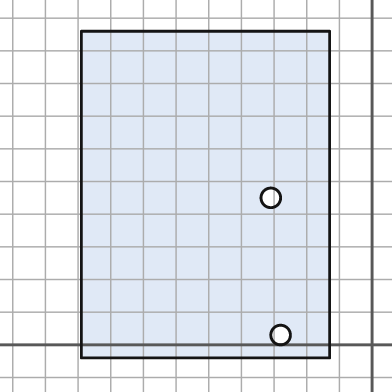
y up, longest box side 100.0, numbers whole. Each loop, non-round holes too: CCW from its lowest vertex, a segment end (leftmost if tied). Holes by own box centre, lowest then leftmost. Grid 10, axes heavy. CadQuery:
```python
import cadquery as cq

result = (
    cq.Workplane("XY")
    .moveTo(-89.0, -4.0)
    .lineTo(-13.0, -4.0)
    .lineTo(-13.0, 96.0)
    .lineTo(-89.0, 96.0)
    .close()
    .moveTo(-28.0, 3.0)
    .circle(3.0)
    .moveTo(-31.0, 45.0)
    .circle(3.0)
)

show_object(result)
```